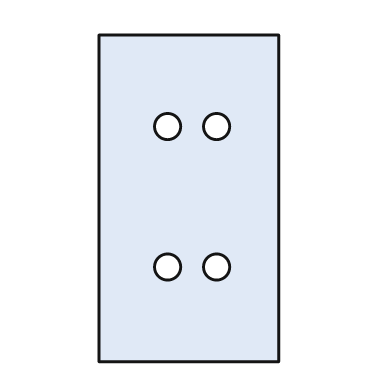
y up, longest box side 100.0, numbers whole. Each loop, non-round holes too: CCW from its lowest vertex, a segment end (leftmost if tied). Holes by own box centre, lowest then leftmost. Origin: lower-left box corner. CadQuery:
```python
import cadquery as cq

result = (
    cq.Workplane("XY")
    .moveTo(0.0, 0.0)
    .lineTo(55.0, 0.0)
    .lineTo(55.0, 100.0)
    .lineTo(0.0, 100.0)
    .close()
    .moveTo(21.0, 29.0)
    .circle(4.0)
    .moveTo(36.0, 29.0)
    .circle(4.0)
    .moveTo(21.0, 72.0)
    .circle(4.0)
    .moveTo(36.0, 72.0)
    .circle(4.0)
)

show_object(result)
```